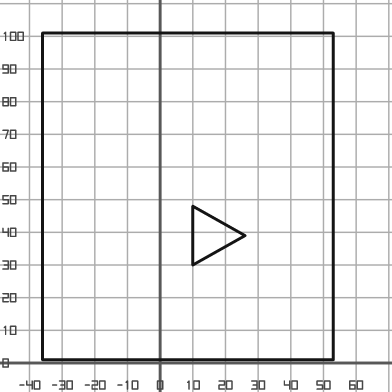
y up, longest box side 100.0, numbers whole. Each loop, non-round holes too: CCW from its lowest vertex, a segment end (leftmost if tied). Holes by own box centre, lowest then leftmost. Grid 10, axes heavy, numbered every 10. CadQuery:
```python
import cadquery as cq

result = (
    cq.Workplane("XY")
    .moveTo(-36.0, 1.0)
    .lineTo(53.0, 1.0)
    .lineTo(53.0, 101.0)
    .lineTo(-36.0, 101.0)
    .close()
    .moveTo(10.0, 30.0)
    .lineTo(26.0, 39.0)
    .lineTo(10.0, 48.0)
    .close()
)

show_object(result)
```